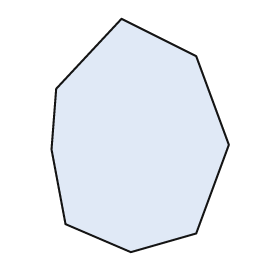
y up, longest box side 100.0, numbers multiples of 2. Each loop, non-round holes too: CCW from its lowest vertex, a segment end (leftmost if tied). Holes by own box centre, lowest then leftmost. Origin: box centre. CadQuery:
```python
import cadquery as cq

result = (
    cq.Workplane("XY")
    .moveTo(-4.0, -50.0)
    .lineTo(24.0, -42.0)
    .lineTo(38.0, -4.0)
    .lineTo(24.0, 34.0)
    .lineTo(-8.0, 50.0)
    .lineTo(-36.0, 20.0)
    .lineTo(-38.0, -6.0)
    .lineTo(-32.0, -38.0)
    .close()
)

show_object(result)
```